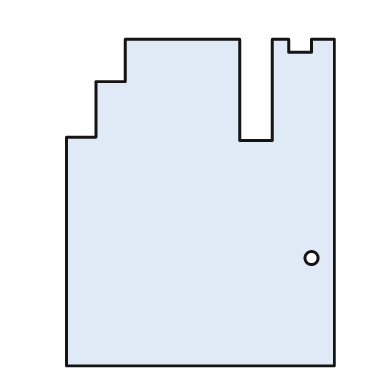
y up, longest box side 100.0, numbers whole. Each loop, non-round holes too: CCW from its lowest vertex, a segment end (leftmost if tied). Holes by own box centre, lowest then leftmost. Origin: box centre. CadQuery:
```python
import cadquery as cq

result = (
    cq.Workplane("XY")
    .moveTo(-41.0, -50.0)
    .lineTo(41.0, -50.0)
    .lineTo(41.0, 50.0)
    .lineTo(34.0, 50.0)
    .lineTo(34.0, 46.0)
    .lineTo(27.0, 46.0)
    .lineTo(27.0, 50.0)
    .lineTo(22.0, 50.0)
    .lineTo(22.0, 19.0)
    .lineTo(12.0, 19.0)
    .lineTo(12.0, 50.0)
    .lineTo(-23.0, 50.0)
    .lineTo(-23.0, 37.0)
    .lineTo(-32.0, 37.0)
    .lineTo(-32.0, 20.0)
    .lineTo(-41.0, 20.0)
    .close()
    .moveTo(34.0, -17.0)
    .circle(2.0)
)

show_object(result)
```